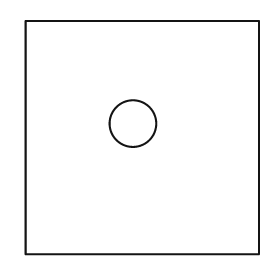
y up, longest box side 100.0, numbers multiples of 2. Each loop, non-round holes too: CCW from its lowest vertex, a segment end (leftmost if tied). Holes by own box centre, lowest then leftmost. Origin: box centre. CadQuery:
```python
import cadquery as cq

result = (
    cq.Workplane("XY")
    .moveTo(-50.0, -50.0)
    .lineTo(50.0, -50.0)
    .lineTo(50.0, 50.0)
    .lineTo(-50.0, 50.0)
    .close()
    .moveTo(-4.0, 6.0)
    .circle(10.0)
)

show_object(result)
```